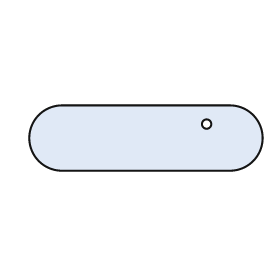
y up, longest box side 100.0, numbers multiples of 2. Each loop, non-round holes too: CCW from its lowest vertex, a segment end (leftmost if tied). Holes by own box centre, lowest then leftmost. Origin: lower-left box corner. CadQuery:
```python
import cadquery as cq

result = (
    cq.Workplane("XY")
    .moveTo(14.0, 0.0)
    .lineTo(86.0, 0.0)
    .threePointArc((100.0, 14.0), (86.0, 28.0))
    .lineTo(14.0, 28.0)
    .threePointArc((0.0, 14.0), (14.0, 0.0))
    .close()
    .moveTo(76.0, 20.0)
    .circle(2.0)
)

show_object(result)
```